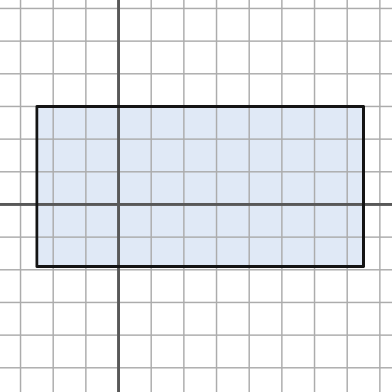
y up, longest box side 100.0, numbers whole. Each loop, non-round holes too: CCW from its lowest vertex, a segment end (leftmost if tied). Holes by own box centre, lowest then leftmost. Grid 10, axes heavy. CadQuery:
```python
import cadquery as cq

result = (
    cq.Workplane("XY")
    .moveTo(-25.0, -19.0)
    .lineTo(75.0, -19.0)
    .lineTo(75.0, 30.0)
    .lineTo(-25.0, 30.0)
    .close()
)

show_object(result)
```